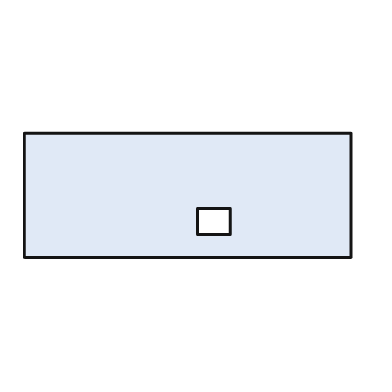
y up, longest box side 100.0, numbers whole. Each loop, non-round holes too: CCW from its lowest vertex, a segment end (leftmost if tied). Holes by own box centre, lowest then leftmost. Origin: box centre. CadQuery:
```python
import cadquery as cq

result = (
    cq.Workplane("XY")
    .moveTo(-50.0, -19.0)
    .lineTo(50.0, -19.0)
    .lineTo(50.0, 19.0)
    .lineTo(-50.0, 19.0)
    .close()
    .moveTo(3.0, -12.0)
    .lineTo(13.0, -12.0)
    .lineTo(13.0, -4.0)
    .lineTo(3.0, -4.0)
    .close()
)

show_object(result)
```